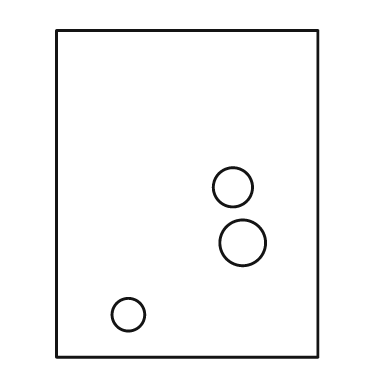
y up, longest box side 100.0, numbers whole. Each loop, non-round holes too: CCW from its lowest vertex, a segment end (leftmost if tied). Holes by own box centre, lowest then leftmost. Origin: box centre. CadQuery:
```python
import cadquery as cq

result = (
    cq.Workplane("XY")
    .moveTo(-40.0, -50.0)
    .lineTo(40.0, -50.0)
    .lineTo(40.0, 50.0)
    .lineTo(-40.0, 50.0)
    .close()
    .moveTo(-18.0, -37.0)
    .circle(5.0)
    .moveTo(17.0, -15.0)
    .circle(7.0)
    .moveTo(14.0, 2.0)
    .circle(6.0)
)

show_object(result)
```